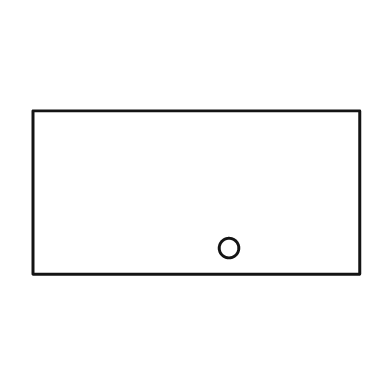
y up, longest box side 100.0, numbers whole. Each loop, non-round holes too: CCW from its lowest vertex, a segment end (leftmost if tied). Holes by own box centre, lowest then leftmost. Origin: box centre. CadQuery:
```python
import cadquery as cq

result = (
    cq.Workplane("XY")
    .moveTo(-50.0, -25.0)
    .lineTo(50.0, -25.0)
    .lineTo(50.0, 25.0)
    .lineTo(-50.0, 25.0)
    .close()
    .moveTo(10.0, -17.0)
    .circle(3.0)
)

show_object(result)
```